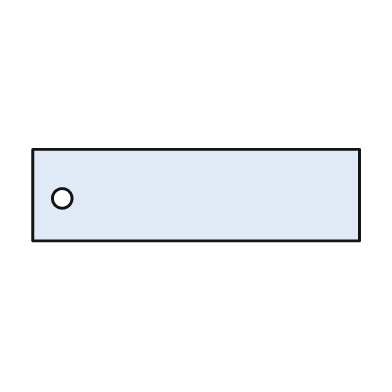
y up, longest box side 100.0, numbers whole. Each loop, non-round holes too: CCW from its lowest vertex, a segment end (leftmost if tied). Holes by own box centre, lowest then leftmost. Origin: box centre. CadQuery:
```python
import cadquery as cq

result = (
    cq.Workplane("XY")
    .moveTo(-50.0, -14.0)
    .lineTo(50.0, -14.0)
    .lineTo(50.0, 14.0)
    .lineTo(-50.0, 14.0)
    .close()
    .moveTo(-41.0, -1.0)
    .circle(3.0)
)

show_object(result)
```